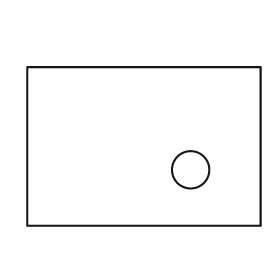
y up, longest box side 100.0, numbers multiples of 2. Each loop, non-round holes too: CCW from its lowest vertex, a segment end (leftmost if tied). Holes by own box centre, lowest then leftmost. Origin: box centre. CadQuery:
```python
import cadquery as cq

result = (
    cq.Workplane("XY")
    .moveTo(-50.0, -34.0)
    .lineTo(50.0, -34.0)
    .lineTo(50.0, 34.0)
    .lineTo(-50.0, 34.0)
    .close()
    .moveTo(20.0, -10.0)
    .circle(8.0)
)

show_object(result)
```